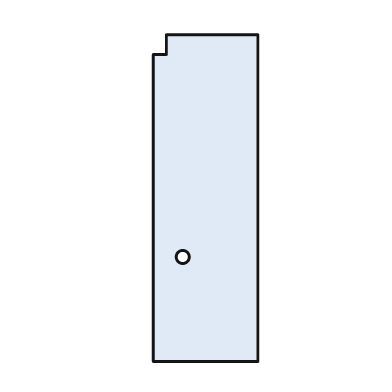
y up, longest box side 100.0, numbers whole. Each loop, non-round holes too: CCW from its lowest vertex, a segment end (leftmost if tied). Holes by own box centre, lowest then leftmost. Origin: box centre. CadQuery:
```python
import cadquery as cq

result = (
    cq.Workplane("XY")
    .moveTo(-16.0, -50.0)
    .lineTo(16.0, -50.0)
    .lineTo(16.0, 50.0)
    .lineTo(-12.0, 50.0)
    .lineTo(-12.0, 44.0)
    .lineTo(-16.0, 44.0)
    .close()
    .moveTo(-7.0, -18.0)
    .circle(2.0)
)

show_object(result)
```